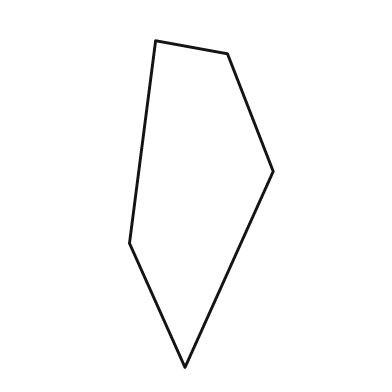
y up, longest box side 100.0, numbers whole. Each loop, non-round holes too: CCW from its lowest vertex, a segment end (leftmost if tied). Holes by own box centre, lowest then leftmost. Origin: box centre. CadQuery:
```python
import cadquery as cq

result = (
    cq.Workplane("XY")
    .moveTo(-5.0, -50.0)
    .lineTo(22.0, 10.0)
    .lineTo(8.0, 46.0)
    .lineTo(-14.0, 50.0)
    .lineTo(-22.0, -12.0)
    .close()
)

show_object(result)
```